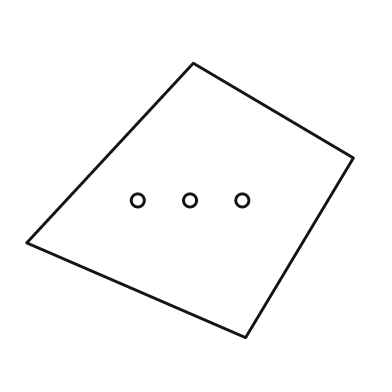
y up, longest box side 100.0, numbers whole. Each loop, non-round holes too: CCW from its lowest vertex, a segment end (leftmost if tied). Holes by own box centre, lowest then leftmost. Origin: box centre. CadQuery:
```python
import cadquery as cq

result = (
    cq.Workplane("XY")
    .moveTo(17.0, -42.0)
    .lineTo(50.0, 13.0)
    .lineTo(1.0, 42.0)
    .lineTo(-50.0, -13.0)
    .close()
    .moveTo(-16.0, 0.0)
    .circle(2.0)
    .moveTo(0.0, 0.0)
    .circle(2.0)
    .moveTo(16.0, 0.0)
    .circle(2.0)
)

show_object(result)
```